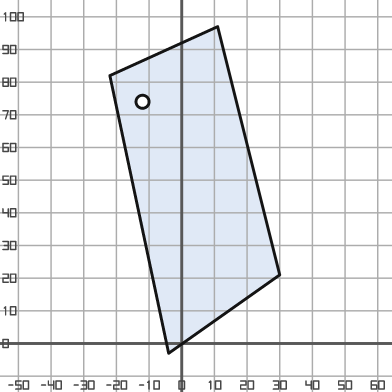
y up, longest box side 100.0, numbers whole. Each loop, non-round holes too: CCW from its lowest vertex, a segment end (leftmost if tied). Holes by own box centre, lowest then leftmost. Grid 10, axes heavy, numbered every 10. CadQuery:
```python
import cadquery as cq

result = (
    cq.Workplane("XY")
    .moveTo(-4.0, -3.0)
    .lineTo(30.0, 21.0)
    .lineTo(11.0, 97.0)
    .lineTo(-22.0, 82.0)
    .close()
    .moveTo(-12.0, 74.0)
    .circle(2.0)
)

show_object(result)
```